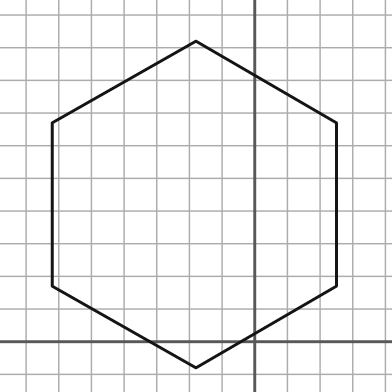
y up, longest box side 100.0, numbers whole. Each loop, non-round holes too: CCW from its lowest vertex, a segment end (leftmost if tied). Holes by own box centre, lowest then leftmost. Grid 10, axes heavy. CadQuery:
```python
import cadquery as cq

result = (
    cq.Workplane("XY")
    .moveTo(-18.0, -8.0)
    .lineTo(25.0, 17.0)
    .lineTo(25.0, 67.0)
    .lineTo(-18.0, 92.0)
    .lineTo(-62.0, 67.0)
    .lineTo(-62.0, 17.0)
    .close()
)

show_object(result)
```